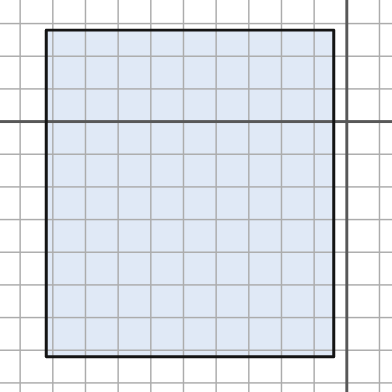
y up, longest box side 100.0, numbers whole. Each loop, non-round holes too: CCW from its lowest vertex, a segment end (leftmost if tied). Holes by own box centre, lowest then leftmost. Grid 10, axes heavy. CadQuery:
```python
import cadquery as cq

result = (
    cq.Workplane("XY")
    .moveTo(-92.0, -72.0)
    .lineTo(-4.0, -72.0)
    .lineTo(-4.0, 28.0)
    .lineTo(-92.0, 28.0)
    .close()
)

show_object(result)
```